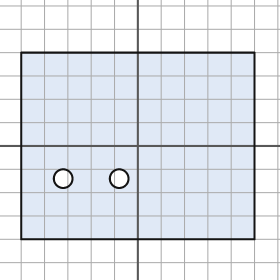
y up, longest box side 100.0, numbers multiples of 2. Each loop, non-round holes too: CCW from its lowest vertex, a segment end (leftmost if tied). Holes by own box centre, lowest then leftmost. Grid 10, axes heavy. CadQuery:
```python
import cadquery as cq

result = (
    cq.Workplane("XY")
    .moveTo(-50.0, -40.0)
    .lineTo(50.0, -40.0)
    .lineTo(50.0, 40.0)
    .lineTo(-50.0, 40.0)
    .close()
    .moveTo(-32.0, -14.0)
    .circle(4.0)
    .moveTo(-8.0, -14.0)
    .circle(4.0)
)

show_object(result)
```